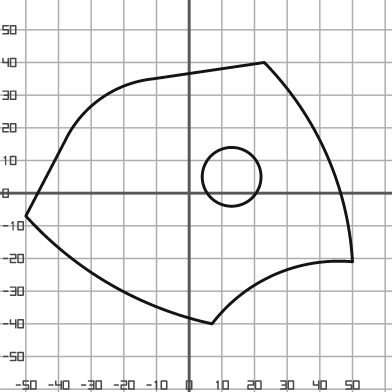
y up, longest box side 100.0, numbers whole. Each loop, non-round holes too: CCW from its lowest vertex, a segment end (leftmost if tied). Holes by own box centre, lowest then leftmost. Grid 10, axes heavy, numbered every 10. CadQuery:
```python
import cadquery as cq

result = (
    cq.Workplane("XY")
    .moveTo(7.0, -40.0)
    .threePointArc((26.0, -25.0), (50.0, -21.0))
    .threePointArc((42.0, 12.0), (23.0, 40.0))
    .lineTo(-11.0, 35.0)
    .threePointArc((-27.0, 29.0), (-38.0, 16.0))
    .lineTo(-50.0, -7.0)
    .threePointArc((-24.0, -28.0), (7.0, -40.0))
    .close()
    .moveTo(13.0, 5.0)
    .circle(9.0)
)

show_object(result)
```